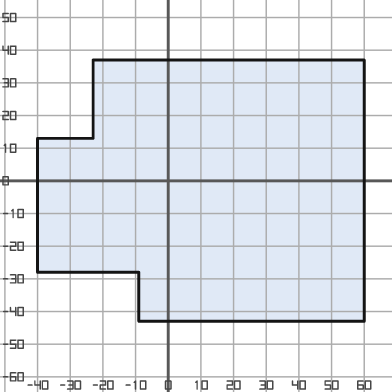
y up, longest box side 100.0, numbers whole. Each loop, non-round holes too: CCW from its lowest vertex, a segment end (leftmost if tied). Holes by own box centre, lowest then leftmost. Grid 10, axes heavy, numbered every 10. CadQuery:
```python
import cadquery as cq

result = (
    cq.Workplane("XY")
    .moveTo(-9.0, -43.0)
    .lineTo(60.0, -43.0)
    .lineTo(60.0, 37.0)
    .lineTo(-23.0, 37.0)
    .lineTo(-23.0, 13.0)
    .lineTo(-40.0, 13.0)
    .lineTo(-40.0, -28.0)
    .lineTo(-9.0, -28.0)
    .close()
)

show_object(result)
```